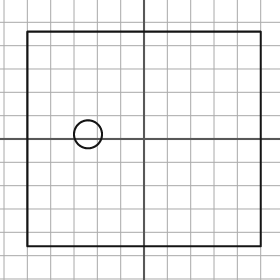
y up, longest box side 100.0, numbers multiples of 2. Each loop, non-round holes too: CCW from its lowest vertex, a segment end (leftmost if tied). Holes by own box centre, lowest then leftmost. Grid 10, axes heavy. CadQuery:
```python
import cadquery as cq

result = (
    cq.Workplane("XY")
    .moveTo(-50.0, -46.0)
    .lineTo(50.0, -46.0)
    .lineTo(50.0, 46.0)
    .lineTo(-50.0, 46.0)
    .close()
    .moveTo(-24.0, 2.0)
    .circle(6.0)
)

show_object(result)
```